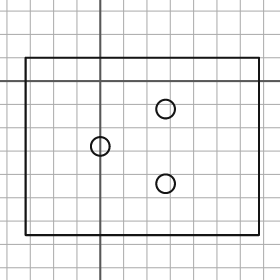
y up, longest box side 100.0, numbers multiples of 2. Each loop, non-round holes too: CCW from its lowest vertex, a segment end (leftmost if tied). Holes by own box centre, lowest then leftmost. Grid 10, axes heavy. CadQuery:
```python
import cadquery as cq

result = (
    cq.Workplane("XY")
    .moveTo(-32.0, -66.0)
    .lineTo(68.0, -66.0)
    .lineTo(68.0, 10.0)
    .lineTo(-32.0, 10.0)
    .close()
    .moveTo(28.0, -44.0)
    .circle(4.0)
    .moveTo(0.0, -28.0)
    .circle(4.0)
    .moveTo(28.0, -12.0)
    .circle(4.0)
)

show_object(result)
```